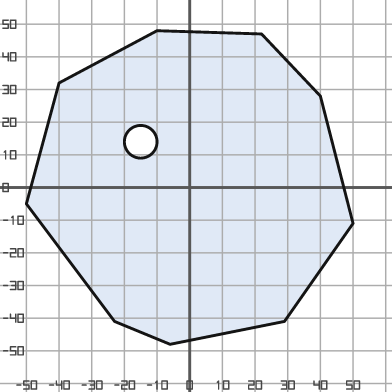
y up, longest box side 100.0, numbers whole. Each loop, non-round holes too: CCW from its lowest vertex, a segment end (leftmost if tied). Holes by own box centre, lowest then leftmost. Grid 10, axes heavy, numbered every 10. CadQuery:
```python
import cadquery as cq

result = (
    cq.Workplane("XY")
    .moveTo(-6.0, -48.0)
    .lineTo(29.0, -41.0)
    .lineTo(50.0, -11.0)
    .lineTo(40.0, 28.0)
    .lineTo(22.0, 47.0)
    .lineTo(-10.0, 48.0)
    .lineTo(-40.0, 32.0)
    .lineTo(-50.0, -5.0)
    .lineTo(-23.0, -41.0)
    .close()
    .moveTo(-15.0, 14.0)
    .circle(5.0)
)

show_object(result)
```